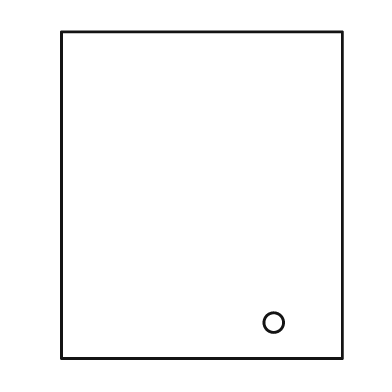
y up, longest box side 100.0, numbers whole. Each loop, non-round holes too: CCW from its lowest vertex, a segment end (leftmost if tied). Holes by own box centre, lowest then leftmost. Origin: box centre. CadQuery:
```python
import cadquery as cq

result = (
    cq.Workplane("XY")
    .moveTo(-43.0, -50.0)
    .lineTo(43.0, -50.0)
    .lineTo(43.0, 50.0)
    .lineTo(-43.0, 50.0)
    .close()
    .moveTo(22.0, -39.0)
    .circle(3.0)
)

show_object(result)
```